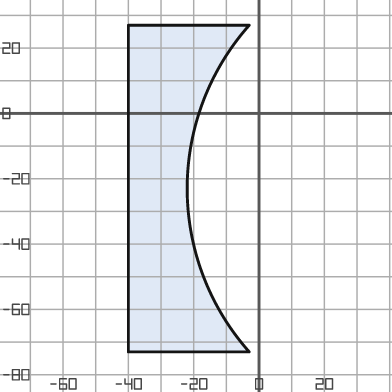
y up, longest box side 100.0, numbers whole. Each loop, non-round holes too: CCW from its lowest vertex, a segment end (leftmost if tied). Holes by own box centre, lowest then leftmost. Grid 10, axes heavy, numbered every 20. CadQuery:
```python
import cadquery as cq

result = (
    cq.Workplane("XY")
    .moveTo(-40.0, -73.0)
    .lineTo(-3.0, -73.0)
    .threePointArc((-22.0, -23.0), (-3.0, 27.0))
    .lineTo(-40.0, 27.0)
    .close()
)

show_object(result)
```